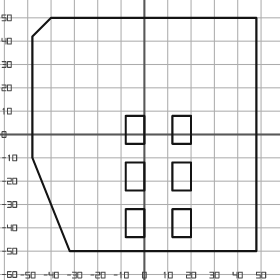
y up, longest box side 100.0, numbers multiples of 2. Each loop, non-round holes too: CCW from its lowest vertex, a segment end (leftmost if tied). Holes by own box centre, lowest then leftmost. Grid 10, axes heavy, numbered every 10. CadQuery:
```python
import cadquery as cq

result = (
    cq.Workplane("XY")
    .moveTo(-32.0, -50.0)
    .lineTo(48.0, -50.0)
    .lineTo(48.0, 50.0)
    .lineTo(-40.0, 50.0)
    .lineTo(-48.0, 42.0)
    .lineTo(-48.0, -10.0)
    .close()
    .moveTo(-8.0, -44.0)
    .lineTo(0.0, -44.0)
    .lineTo(0.0, -32.0)
    .lineTo(-8.0, -32.0)
    .close()
    .moveTo(12.0, -44.0)
    .lineTo(20.0, -44.0)
    .lineTo(20.0, -32.0)
    .lineTo(12.0, -32.0)
    .close()
    .moveTo(-8.0, -24.0)
    .lineTo(0.0, -24.0)
    .lineTo(0.0, -12.0)
    .lineTo(-8.0, -12.0)
    .close()
    .moveTo(12.0, -24.0)
    .lineTo(20.0, -24.0)
    .lineTo(20.0, -12.0)
    .lineTo(12.0, -12.0)
    .close()
    .moveTo(-8.0, -4.0)
    .lineTo(0.0, -4.0)
    .lineTo(0.0, 8.0)
    .lineTo(-8.0, 8.0)
    .close()
    .moveTo(12.0, -4.0)
    .lineTo(20.0, -4.0)
    .lineTo(20.0, 8.0)
    .lineTo(12.0, 8.0)
    .close()
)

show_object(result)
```